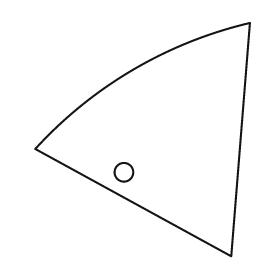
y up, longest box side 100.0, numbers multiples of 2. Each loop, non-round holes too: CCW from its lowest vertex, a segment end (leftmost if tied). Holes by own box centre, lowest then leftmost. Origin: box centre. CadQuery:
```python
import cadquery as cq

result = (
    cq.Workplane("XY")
    .moveTo(38.0, -50.0)
    .lineTo(46.0, 50.0)
    .threePointArc((-4.0, 30.0), (-46.0, -4.0))
    .close()
    .moveTo(-8.0, -14.0)
    .circle(4.0)
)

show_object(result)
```